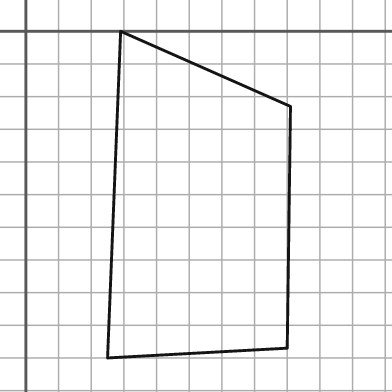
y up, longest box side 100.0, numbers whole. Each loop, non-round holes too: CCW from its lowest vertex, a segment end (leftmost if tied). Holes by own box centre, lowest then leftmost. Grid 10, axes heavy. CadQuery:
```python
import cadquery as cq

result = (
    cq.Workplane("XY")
    .moveTo(25.0, -100.0)
    .lineTo(80.0, -97.0)
    .lineTo(81.0, -23.0)
    .lineTo(29.0, 0.0)
    .close()
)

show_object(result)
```